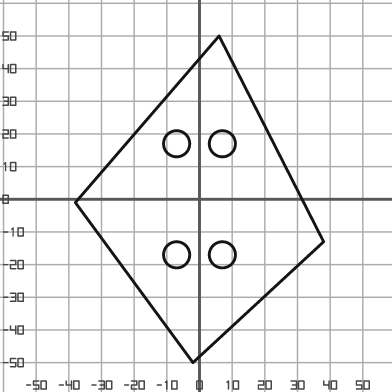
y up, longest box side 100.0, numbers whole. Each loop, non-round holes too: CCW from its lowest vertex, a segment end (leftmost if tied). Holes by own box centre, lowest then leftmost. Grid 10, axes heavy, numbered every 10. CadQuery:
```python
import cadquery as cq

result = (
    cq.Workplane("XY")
    .moveTo(-2.0, -50.0)
    .lineTo(38.0, -13.0)
    .lineTo(6.0, 50.0)
    .lineTo(-38.0, -1.0)
    .close()
    .moveTo(-7.0, -17.0)
    .circle(4.0)
    .moveTo(7.0, -17.0)
    .circle(4.0)
    .moveTo(-7.0, 17.0)
    .circle(4.0)
    .moveTo(7.0, 17.0)
    .circle(4.0)
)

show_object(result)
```